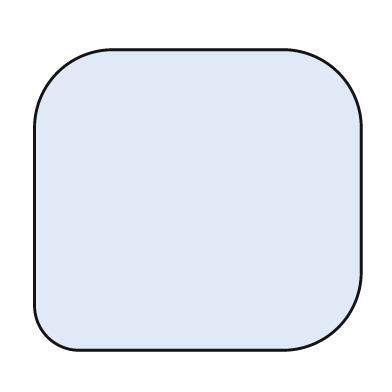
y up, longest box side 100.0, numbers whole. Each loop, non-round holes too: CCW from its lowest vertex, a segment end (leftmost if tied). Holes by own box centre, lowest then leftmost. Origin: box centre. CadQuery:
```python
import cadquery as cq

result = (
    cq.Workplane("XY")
    .moveTo(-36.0, -46.0)
    .lineTo(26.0, -46.0)
    .threePointArc((43.0, -39.0), (50.0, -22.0))
    .lineTo(50.0, 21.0)
    .threePointArc((43.0, 39.0), (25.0, 46.0))
    .lineTo(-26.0, 46.0)
    .threePointArc((-43.0, 39.0), (-50.0, 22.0))
    .lineTo(-50.0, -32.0)
    .threePointArc((-46.0, -42.0), (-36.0, -46.0))
    .close()
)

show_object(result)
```